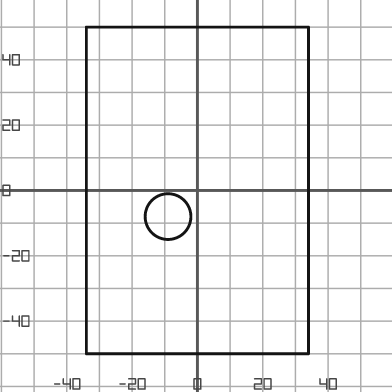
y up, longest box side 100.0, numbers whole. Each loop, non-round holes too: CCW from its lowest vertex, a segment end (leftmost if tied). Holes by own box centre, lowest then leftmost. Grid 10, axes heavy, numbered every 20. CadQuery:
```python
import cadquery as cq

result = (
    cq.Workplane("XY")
    .moveTo(-34.0, -50.0)
    .lineTo(34.0, -50.0)
    .lineTo(34.0, 50.0)
    .lineTo(-34.0, 50.0)
    .close()
    .moveTo(-9.0, -8.0)
    .circle(7.0)
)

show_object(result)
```